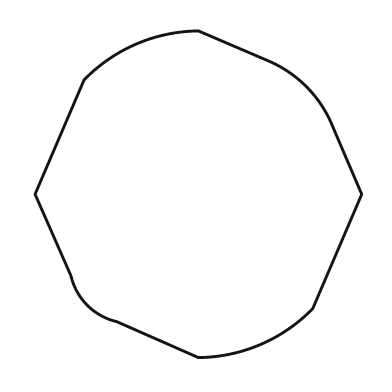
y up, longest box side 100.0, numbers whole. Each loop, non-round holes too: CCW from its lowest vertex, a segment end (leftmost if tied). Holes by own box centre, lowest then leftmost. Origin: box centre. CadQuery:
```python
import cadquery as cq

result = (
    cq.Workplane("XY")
    .moveTo(0.0, -50.0)
    .threePointArc((19.0, -46.0), (35.0, -35.0))
    .lineTo(50.0, 0.0)
    .lineTo(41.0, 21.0)
    .threePointArc((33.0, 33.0), (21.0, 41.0))
    .lineTo(0.0, 50.0)
    .threePointArc((-19.0, 46.0), (-35.0, 35.0))
    .lineTo(-50.0, 0.0)
    .lineTo(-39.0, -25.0)
    .threePointArc((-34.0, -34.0), (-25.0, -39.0))
    .close()
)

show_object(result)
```